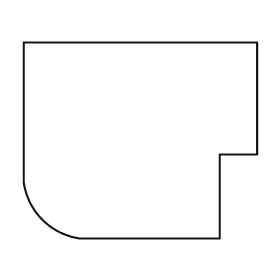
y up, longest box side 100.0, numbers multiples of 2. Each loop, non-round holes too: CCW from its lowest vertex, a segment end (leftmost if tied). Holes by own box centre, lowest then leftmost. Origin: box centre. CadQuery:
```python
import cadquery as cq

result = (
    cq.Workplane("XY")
    .moveTo(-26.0, -42.0)
    .lineTo(34.0, -42.0)
    .lineTo(34.0, -6.0)
    .lineTo(50.0, -6.0)
    .lineTo(50.0, 42.0)
    .lineTo(-50.0, 42.0)
    .lineTo(-50.0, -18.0)
    .threePointArc((-42.0, -34.0), (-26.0, -42.0))
    .close()
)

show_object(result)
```